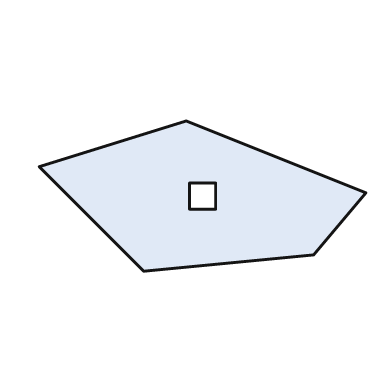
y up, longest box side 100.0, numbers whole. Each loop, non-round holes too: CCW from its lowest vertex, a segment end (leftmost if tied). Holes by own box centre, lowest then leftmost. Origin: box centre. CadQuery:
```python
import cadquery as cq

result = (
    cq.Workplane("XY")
    .moveTo(-18.0, -23.0)
    .lineTo(34.0, -18.0)
    .lineTo(50.0, 1.0)
    .lineTo(-5.0, 23.0)
    .lineTo(-50.0, 9.0)
    .close()
    .moveTo(-4.0, -4.0)
    .lineTo(4.0, -4.0)
    .lineTo(4.0, 4.0)
    .lineTo(-4.0, 4.0)
    .close()
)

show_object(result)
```